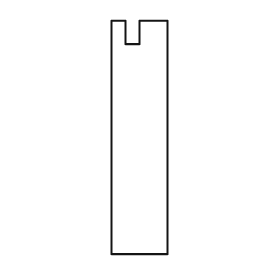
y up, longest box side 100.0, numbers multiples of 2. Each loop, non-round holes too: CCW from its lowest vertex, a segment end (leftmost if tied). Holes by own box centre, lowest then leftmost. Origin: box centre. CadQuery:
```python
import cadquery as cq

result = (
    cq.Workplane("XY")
    .moveTo(-12.0, -50.0)
    .lineTo(12.0, -50.0)
    .lineTo(12.0, 50.0)
    .lineTo(0.0, 50.0)
    .lineTo(0.0, 40.0)
    .lineTo(-6.0, 40.0)
    .lineTo(-6.0, 50.0)
    .lineTo(-12.0, 50.0)
    .close()
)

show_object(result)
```